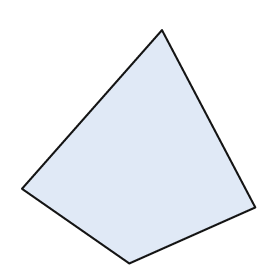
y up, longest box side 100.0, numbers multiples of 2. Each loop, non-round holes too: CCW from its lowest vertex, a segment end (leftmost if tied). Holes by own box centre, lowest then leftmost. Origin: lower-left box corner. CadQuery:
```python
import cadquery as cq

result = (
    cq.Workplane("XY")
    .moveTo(46.0, 0.0)
    .lineTo(100.0, 24.0)
    .lineTo(60.0, 100.0)
    .lineTo(0.0, 32.0)
    .close()
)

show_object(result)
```